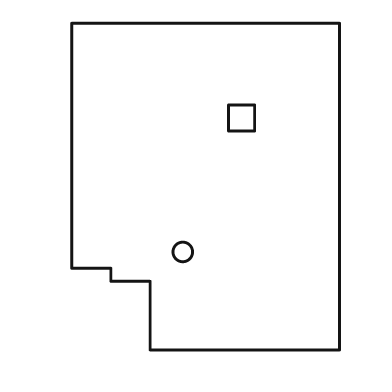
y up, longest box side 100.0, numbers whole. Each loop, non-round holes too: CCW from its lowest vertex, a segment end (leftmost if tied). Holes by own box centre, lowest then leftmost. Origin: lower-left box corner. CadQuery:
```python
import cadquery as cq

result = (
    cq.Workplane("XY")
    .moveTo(24.0, 0.0)
    .lineTo(82.0, 0.0)
    .lineTo(82.0, 100.0)
    .lineTo(0.0, 100.0)
    .lineTo(0.0, 25.0)
    .lineTo(12.0, 25.0)
    .lineTo(12.0, 21.0)
    .lineTo(24.0, 21.0)
    .close()
    .moveTo(34.0, 30.0)
    .circle(3.0)
    .moveTo(48.0, 67.0)
    .lineTo(56.0, 67.0)
    .lineTo(56.0, 75.0)
    .lineTo(48.0, 75.0)
    .close()
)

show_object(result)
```